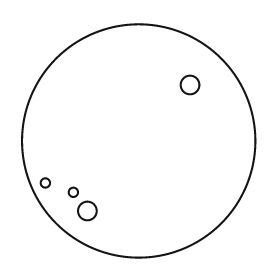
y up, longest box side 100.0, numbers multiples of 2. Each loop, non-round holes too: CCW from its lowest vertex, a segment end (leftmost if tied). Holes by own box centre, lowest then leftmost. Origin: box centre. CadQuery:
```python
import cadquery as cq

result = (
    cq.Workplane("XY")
    .moveTo(0.0, 0.0)
    .circle(50.0)
    .moveTo(-22.0, -30.0)
    .circle(4.0)
    .moveTo(-28.0, -22.0)
    .circle(2.0)
    .moveTo(-40.0, -18.0)
    .circle(2.0)
    .moveTo(22.0, 24.0)
    .circle(4.0)
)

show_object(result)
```